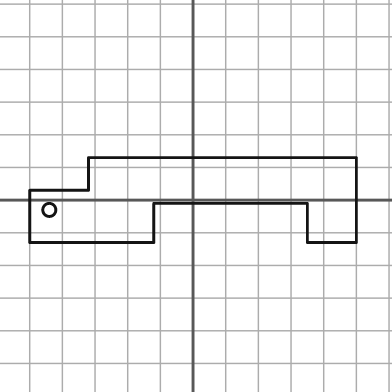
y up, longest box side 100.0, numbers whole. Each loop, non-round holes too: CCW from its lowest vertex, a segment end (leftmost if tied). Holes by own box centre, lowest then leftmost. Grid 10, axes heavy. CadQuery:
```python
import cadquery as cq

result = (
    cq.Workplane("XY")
    .moveTo(-50.0, -13.0)
    .lineTo(-12.0, -13.0)
    .lineTo(-12.0, -1.0)
    .lineTo(35.0, -1.0)
    .lineTo(35.0, -13.0)
    .lineTo(50.0, -13.0)
    .lineTo(50.0, 13.0)
    .lineTo(-32.0, 13.0)
    .lineTo(-32.0, 3.0)
    .lineTo(-50.0, 3.0)
    .close()
    .moveTo(-44.0, -3.0)
    .circle(2.0)
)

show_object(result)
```